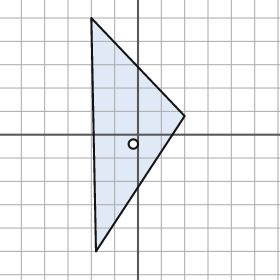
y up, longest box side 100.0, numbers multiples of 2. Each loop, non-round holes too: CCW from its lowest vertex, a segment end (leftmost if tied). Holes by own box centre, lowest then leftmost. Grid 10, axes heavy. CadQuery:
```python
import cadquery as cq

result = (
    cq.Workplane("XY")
    .moveTo(-18.0, -50.0)
    .lineTo(20.0, 8.0)
    .lineTo(-20.0, 50.0)
    .close()
    .moveTo(-2.0, -4.0)
    .circle(2.0)
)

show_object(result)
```